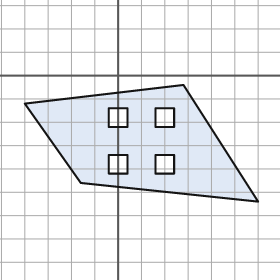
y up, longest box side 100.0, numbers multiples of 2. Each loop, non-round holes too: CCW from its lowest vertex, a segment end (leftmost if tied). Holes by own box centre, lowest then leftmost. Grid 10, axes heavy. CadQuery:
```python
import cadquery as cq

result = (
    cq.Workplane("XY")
    .moveTo(60.0, -54.0)
    .lineTo(28.0, -4.0)
    .lineTo(-40.0, -12.0)
    .lineTo(-16.0, -46.0)
    .close()
    .moveTo(-4.0, -42.0)
    .lineTo(4.0, -42.0)
    .lineTo(4.0, -34.0)
    .lineTo(-4.0, -34.0)
    .close()
    .moveTo(16.0, -42.0)
    .lineTo(24.0, -42.0)
    .lineTo(24.0, -34.0)
    .lineTo(16.0, -34.0)
    .close()
    .moveTo(-4.0, -22.0)
    .lineTo(4.0, -22.0)
    .lineTo(4.0, -14.0)
    .lineTo(-4.0, -14.0)
    .close()
    .moveTo(16.0, -22.0)
    .lineTo(24.0, -22.0)
    .lineTo(24.0, -14.0)
    .lineTo(16.0, -14.0)
    .close()
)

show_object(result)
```